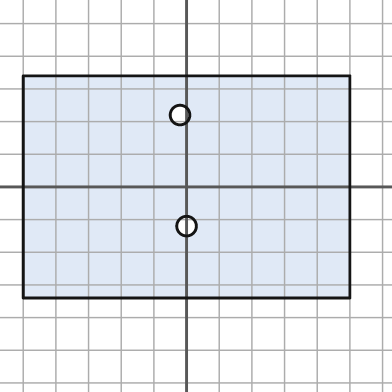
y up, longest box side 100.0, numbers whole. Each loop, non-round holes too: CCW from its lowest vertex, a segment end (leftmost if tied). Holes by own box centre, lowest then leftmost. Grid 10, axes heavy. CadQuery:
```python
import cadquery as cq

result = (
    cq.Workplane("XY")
    .moveTo(-50.0, -34.0)
    .lineTo(50.0, -34.0)
    .lineTo(50.0, 34.0)
    .lineTo(-50.0, 34.0)
    .close()
    .moveTo(0.0, -12.0)
    .circle(3.0)
    .moveTo(-2.0, 22.0)
    .circle(3.0)
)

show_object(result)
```